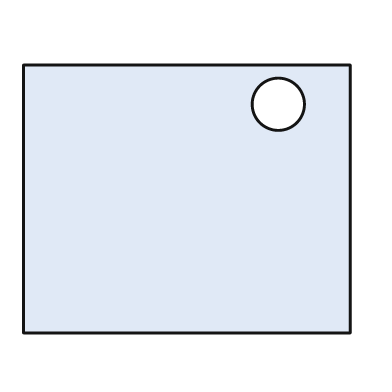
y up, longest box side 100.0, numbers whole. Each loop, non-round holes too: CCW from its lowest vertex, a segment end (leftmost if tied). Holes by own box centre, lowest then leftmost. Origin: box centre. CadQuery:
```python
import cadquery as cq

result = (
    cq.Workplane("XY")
    .moveTo(-50.0, -41.0)
    .lineTo(50.0, -41.0)
    .lineTo(50.0, 41.0)
    .lineTo(-50.0, 41.0)
    .close()
    .moveTo(28.0, 29.0)
    .circle(8.0)
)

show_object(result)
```